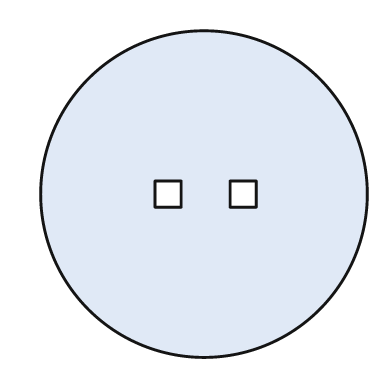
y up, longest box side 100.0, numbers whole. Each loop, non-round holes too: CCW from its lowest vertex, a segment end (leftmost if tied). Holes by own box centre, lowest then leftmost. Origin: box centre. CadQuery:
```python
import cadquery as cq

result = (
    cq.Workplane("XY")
    .moveTo(0.0, 0.0)
    .circle(50.0)
    .moveTo(-15.0, -4.0)
    .lineTo(-7.0, -4.0)
    .lineTo(-7.0, 4.0)
    .lineTo(-15.0, 4.0)
    .close()
    .moveTo(8.0, -4.0)
    .lineTo(16.0, -4.0)
    .lineTo(16.0, 4.0)
    .lineTo(8.0, 4.0)
    .close()
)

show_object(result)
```